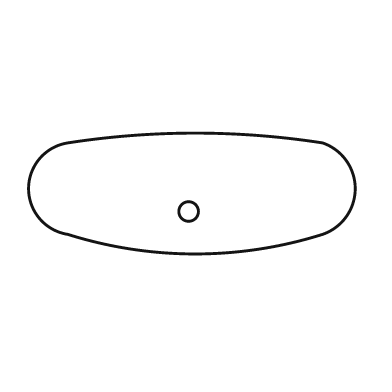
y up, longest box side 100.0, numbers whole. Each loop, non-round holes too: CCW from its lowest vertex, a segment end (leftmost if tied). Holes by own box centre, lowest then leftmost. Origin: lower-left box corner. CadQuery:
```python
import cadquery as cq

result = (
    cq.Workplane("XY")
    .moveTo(12.0, 6.0)
    .threePointArc((51.0, 0.0), (90.0, 6.0))
    .threePointArc((100.0, 20.0), (90.0, 34.0))
    .threePointArc((51.0, 37.0), (12.0, 34.0))
    .threePointArc((0.0, 20.0), (12.0, 6.0))
    .close()
    .moveTo(49.0, 13.0)
    .circle(3.0)
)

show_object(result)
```